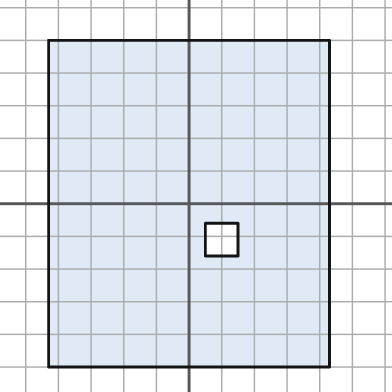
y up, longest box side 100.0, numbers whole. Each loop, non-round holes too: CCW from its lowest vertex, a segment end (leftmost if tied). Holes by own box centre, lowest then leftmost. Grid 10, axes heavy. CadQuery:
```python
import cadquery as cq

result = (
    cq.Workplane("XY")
    .moveTo(-43.0, -50.0)
    .lineTo(43.0, -50.0)
    .lineTo(43.0, 50.0)
    .lineTo(-43.0, 50.0)
    .close()
    .moveTo(5.0, -16.0)
    .lineTo(15.0, -16.0)
    .lineTo(15.0, -6.0)
    .lineTo(5.0, -6.0)
    .close()
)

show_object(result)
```